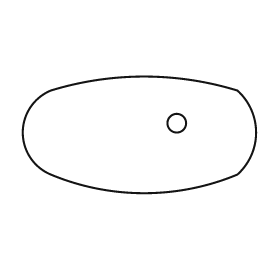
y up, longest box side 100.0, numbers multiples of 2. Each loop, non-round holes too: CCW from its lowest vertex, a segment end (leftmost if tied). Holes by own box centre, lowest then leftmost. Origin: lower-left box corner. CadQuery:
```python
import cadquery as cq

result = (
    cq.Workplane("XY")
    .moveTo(12.0, 8.0)
    .threePointArc((52.0, 0.0), (92.0, 8.0))
    .threePointArc((100.0, 26.0), (92.0, 44.0))
    .threePointArc((52.0, 50.0), (12.0, 44.0))
    .threePointArc((0.0, 26.0), (12.0, 8.0))
    .close()
    .moveTo(66.0, 30.0)
    .circle(4.0)
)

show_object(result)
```